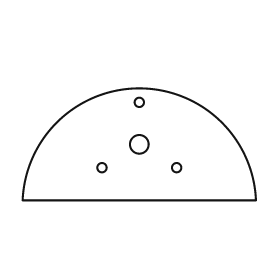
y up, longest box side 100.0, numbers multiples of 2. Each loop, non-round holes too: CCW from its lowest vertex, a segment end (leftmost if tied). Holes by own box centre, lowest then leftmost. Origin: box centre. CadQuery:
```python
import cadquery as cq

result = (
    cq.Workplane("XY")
    .moveTo(-50.0, -24.0)
    .lineTo(50.0, -24.0)
    .threePointArc((0.0, 24.0), (-50.0, -24.0))
    .close()
    .moveTo(-16.0, -10.0)
    .circle(2.0)
    .moveTo(16.0, -10.0)
    .circle(2.0)
    .moveTo(0.0, 0.0)
    .circle(4.0)
    .moveTo(0.0, 18.0)
    .circle(2.0)
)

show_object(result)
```